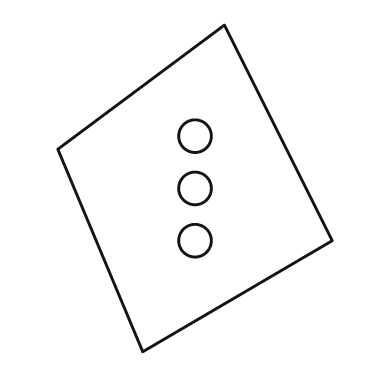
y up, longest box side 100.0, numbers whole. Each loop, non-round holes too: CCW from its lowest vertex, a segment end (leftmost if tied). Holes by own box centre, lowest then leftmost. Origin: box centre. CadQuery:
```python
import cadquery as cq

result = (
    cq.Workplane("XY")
    .moveTo(-16.0, -50.0)
    .lineTo(42.0, -16.0)
    .lineTo(9.0, 50.0)
    .lineTo(-42.0, 12.0)
    .close()
    .moveTo(0.0, -16.0)
    .circle(5.0)
    .moveTo(0.0, 0.0)
    .circle(5.0)
    .moveTo(0.0, 16.0)
    .circle(5.0)
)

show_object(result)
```